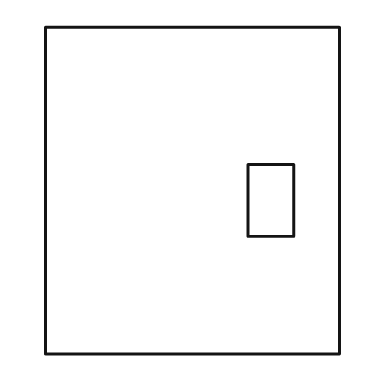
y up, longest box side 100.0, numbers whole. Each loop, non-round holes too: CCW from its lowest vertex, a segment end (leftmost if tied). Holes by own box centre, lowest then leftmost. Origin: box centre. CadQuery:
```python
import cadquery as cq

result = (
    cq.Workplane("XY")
    .moveTo(-45.0, -50.0)
    .lineTo(45.0, -50.0)
    .lineTo(45.0, 50.0)
    .lineTo(-45.0, 50.0)
    .close()
    .moveTo(17.0, -14.0)
    .lineTo(31.0, -14.0)
    .lineTo(31.0, 8.0)
    .lineTo(17.0, 8.0)
    .close()
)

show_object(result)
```